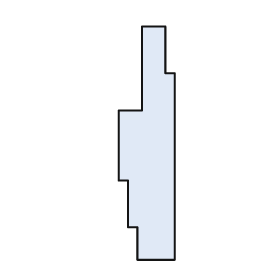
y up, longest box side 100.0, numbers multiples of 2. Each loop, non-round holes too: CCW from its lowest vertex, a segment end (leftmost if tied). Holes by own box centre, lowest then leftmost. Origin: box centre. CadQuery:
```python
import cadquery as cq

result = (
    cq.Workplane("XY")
    .moveTo(-4.0, -50.0)
    .lineTo(12.0, -50.0)
    .lineTo(12.0, 30.0)
    .lineTo(8.0, 30.0)
    .lineTo(8.0, 50.0)
    .lineTo(-2.0, 50.0)
    .lineTo(-2.0, 14.0)
    .lineTo(-12.0, 14.0)
    .lineTo(-12.0, -16.0)
    .lineTo(-8.0, -16.0)
    .lineTo(-8.0, -36.0)
    .lineTo(-4.0, -36.0)
    .close()
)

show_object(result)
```